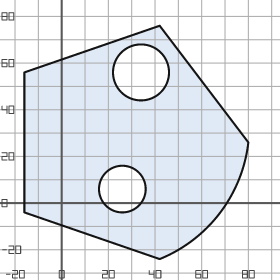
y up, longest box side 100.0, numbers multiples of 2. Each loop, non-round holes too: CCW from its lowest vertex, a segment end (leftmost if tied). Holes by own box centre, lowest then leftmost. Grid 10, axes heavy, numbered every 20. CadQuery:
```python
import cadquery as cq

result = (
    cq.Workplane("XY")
    .moveTo(42.0, -24.0)
    .threePointArc((68.0, -4.0), (80.0, 26.0))
    .lineTo(42.0, 76.0)
    .lineTo(-16.0, 56.0)
    .lineTo(-16.0, -4.0)
    .close()
    .moveTo(26.0, 6.0)
    .circle(10.0)
    .moveTo(34.0, 56.0)
    .circle(12.0)
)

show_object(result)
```